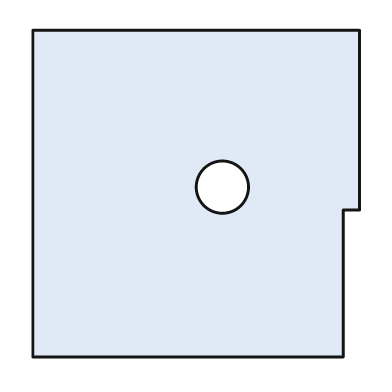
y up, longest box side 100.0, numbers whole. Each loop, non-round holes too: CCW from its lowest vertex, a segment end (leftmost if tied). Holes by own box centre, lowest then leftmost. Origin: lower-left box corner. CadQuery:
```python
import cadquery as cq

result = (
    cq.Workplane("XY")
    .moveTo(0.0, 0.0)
    .lineTo(95.0, 0.0)
    .lineTo(95.0, 45.0)
    .lineTo(100.0, 45.0)
    .lineTo(100.0, 100.0)
    .lineTo(0.0, 100.0)
    .close()
    .moveTo(58.0, 52.0)
    .circle(8.0)
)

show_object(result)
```